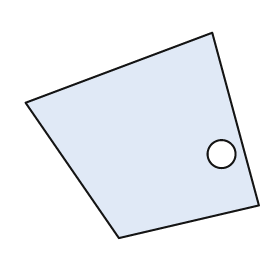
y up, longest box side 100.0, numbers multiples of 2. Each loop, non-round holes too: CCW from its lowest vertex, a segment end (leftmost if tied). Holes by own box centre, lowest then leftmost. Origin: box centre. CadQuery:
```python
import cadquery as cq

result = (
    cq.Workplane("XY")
    .moveTo(-10.0, -44.0)
    .lineTo(50.0, -30.0)
    .lineTo(30.0, 44.0)
    .lineTo(-50.0, 14.0)
    .close()
    .moveTo(34.0, -8.0)
    .circle(6.0)
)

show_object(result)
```